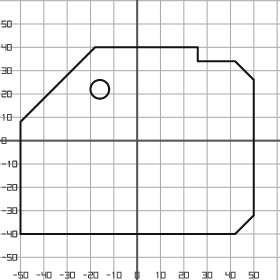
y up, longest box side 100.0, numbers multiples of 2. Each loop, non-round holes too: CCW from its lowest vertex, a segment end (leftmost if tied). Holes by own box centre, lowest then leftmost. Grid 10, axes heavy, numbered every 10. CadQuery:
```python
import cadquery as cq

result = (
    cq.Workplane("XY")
    .moveTo(-50.0, -40.0)
    .lineTo(42.0, -40.0)
    .lineTo(50.0, -32.0)
    .lineTo(50.0, 26.0)
    .lineTo(42.0, 34.0)
    .lineTo(26.0, 34.0)
    .lineTo(26.0, 40.0)
    .lineTo(-18.0, 40.0)
    .lineTo(-50.0, 8.0)
    .close()
    .moveTo(-16.0, 22.0)
    .circle(4.0)
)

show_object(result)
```